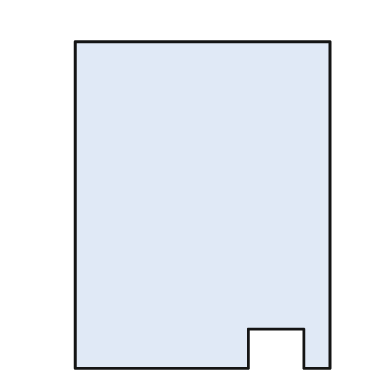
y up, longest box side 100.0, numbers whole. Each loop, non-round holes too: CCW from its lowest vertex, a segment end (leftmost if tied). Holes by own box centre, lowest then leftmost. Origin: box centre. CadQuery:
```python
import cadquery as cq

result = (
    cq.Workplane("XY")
    .moveTo(-39.0, -50.0)
    .lineTo(14.0, -50.0)
    .lineTo(14.0, -38.0)
    .lineTo(31.0, -38.0)
    .lineTo(31.0, -50.0)
    .lineTo(39.0, -50.0)
    .lineTo(39.0, 50.0)
    .lineTo(-39.0, 50.0)
    .close()
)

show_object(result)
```